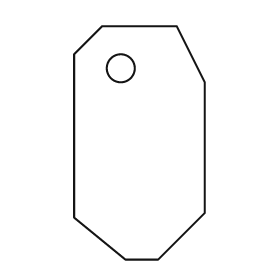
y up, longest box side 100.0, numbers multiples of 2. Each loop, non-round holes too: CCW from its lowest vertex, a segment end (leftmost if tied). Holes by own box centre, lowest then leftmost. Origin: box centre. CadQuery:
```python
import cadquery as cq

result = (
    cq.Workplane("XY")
    .moveTo(-6.0, -50.0)
    .lineTo(8.0, -50.0)
    .lineTo(28.0, -30.0)
    .lineTo(28.0, 26.0)
    .lineTo(16.0, 50.0)
    .lineTo(-16.0, 50.0)
    .lineTo(-28.0, 38.0)
    .lineTo(-28.0, -32.0)
    .close()
    .moveTo(-8.0, 32.0)
    .circle(6.0)
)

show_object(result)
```